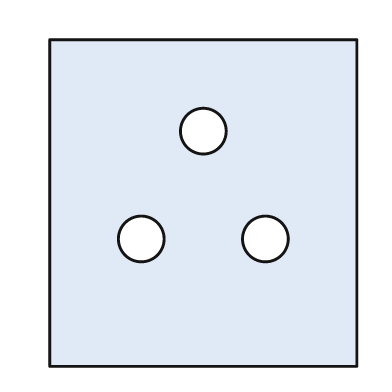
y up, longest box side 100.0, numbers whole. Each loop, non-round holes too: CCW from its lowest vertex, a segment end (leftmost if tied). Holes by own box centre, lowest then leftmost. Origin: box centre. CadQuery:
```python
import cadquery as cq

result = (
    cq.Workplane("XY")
    .moveTo(-47.0, -50.0)
    .lineTo(47.0, -50.0)
    .lineTo(47.0, 50.0)
    .lineTo(-47.0, 50.0)
    .close()
    .moveTo(-19.0, -11.0)
    .circle(7.0)
    .moveTo(19.0, -11.0)
    .circle(7.0)
    .moveTo(0.0, 22.0)
    .circle(7.0)
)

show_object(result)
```